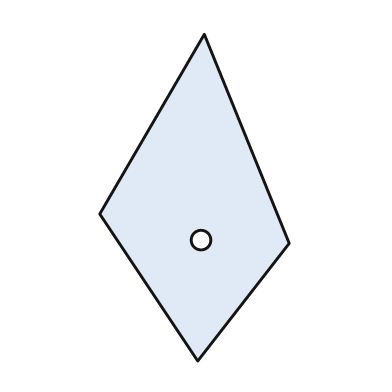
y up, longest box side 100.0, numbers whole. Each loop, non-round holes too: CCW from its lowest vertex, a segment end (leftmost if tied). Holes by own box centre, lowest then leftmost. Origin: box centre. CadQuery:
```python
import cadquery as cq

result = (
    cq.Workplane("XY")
    .moveTo(1.0, -50.0)
    .lineTo(29.0, -14.0)
    .lineTo(3.0, 50.0)
    .lineTo(-29.0, -5.0)
    .close()
    .moveTo(2.0, -13.0)
    .circle(3.0)
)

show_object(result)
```